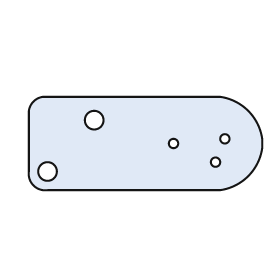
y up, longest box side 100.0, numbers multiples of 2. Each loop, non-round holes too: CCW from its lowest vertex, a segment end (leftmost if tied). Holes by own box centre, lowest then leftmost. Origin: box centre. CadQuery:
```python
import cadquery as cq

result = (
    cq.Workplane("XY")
    .moveTo(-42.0, -20.0)
    .lineTo(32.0, -20.0)
    .threePointArc((44.0, -14.0), (50.0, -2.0))
    .lineTo(50.0, 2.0)
    .threePointArc((44.0, 14.0), (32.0, 20.0))
    .lineTo(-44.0, 20.0)
    .threePointArc((-48.0, 18.0), (-50.0, 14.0))
    .lineTo(-50.0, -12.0)
    .threePointArc((-48.0, -18.0), (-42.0, -20.0))
    .close()
    .moveTo(-42.0, -12.0)
    .circle(4.0)
    .moveTo(30.0, -8.0)
    .circle(2.0)
    .moveTo(12.0, 0.0)
    .circle(2.0)
    .moveTo(34.0, 2.0)
    .circle(2.0)
    .moveTo(-22.0, 10.0)
    .circle(4.0)
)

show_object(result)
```